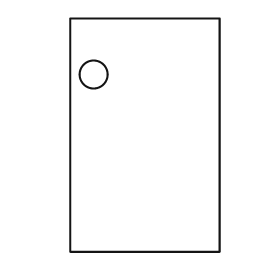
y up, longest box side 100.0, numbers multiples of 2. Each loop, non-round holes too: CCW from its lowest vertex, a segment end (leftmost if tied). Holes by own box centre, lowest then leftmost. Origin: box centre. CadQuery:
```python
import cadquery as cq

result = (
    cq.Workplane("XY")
    .moveTo(-32.0, -50.0)
    .lineTo(32.0, -50.0)
    .lineTo(32.0, 50.0)
    .lineTo(-32.0, 50.0)
    .close()
    .moveTo(-22.0, 26.0)
    .circle(6.0)
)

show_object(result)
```